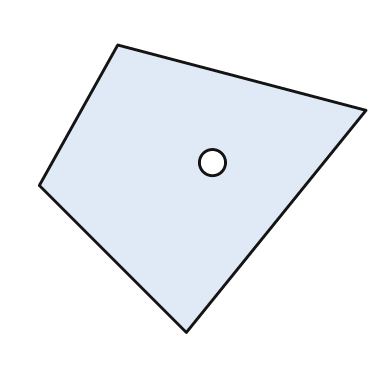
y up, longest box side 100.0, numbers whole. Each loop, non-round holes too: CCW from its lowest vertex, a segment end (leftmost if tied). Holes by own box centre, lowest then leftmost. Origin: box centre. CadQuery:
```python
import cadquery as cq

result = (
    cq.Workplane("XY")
    .moveTo(-5.0, -44.0)
    .lineTo(50.0, 24.0)
    .lineTo(-26.0, 44.0)
    .lineTo(-50.0, 1.0)
    .close()
    .moveTo(3.0, 8.0)
    .circle(4.0)
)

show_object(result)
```